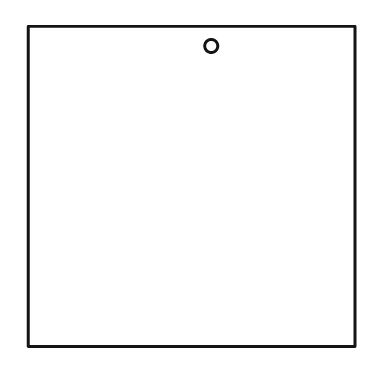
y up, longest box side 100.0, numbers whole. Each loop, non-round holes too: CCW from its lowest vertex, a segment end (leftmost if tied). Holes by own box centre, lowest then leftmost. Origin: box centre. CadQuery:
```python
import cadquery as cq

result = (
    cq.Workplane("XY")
    .moveTo(-50.0, -49.0)
    .lineTo(50.0, -49.0)
    .lineTo(50.0, 49.0)
    .lineTo(-50.0, 49.0)
    .close()
    .moveTo(6.0, 43.0)
    .circle(2.0)
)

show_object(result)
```